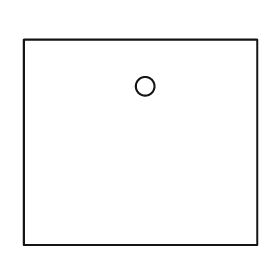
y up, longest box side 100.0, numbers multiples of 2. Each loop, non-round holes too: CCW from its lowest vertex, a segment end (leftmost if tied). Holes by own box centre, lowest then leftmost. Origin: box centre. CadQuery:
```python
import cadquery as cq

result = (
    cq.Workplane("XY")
    .moveTo(-50.0, -44.0)
    .lineTo(50.0, -44.0)
    .lineTo(50.0, 44.0)
    .lineTo(-50.0, 44.0)
    .close()
    .moveTo(2.0, 24.0)
    .circle(4.0)
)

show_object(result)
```